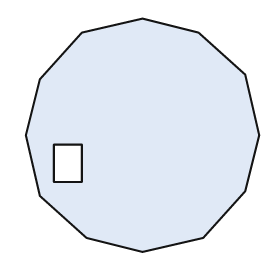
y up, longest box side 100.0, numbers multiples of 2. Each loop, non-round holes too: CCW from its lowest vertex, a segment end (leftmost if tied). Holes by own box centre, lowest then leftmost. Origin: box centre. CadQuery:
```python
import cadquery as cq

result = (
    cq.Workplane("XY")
    .moveTo(0.0, -50.0)
    .lineTo(26.0, -44.0)
    .lineTo(44.0, -24.0)
    .lineTo(50.0, 0.0)
    .lineTo(44.0, 26.0)
    .lineTo(24.0, 44.0)
    .lineTo(0.0, 50.0)
    .lineTo(-26.0, 44.0)
    .lineTo(-44.0, 24.0)
    .lineTo(-50.0, 0.0)
    .lineTo(-44.0, -26.0)
    .lineTo(-24.0, -44.0)
    .close()
    .moveTo(-38.0, -20.0)
    .lineTo(-26.0, -20.0)
    .lineTo(-26.0, -4.0)
    .lineTo(-38.0, -4.0)
    .close()
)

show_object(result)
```